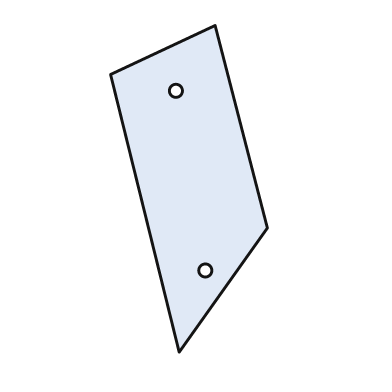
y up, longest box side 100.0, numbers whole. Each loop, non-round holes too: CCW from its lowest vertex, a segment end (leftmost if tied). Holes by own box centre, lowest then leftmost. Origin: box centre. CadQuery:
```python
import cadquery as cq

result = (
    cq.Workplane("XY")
    .moveTo(-3.0, -50.0)
    .lineTo(24.0, -12.0)
    .lineTo(8.0, 50.0)
    .lineTo(-24.0, 35.0)
    .close()
    .moveTo(5.0, -25.0)
    .circle(2.0)
    .moveTo(-4.0, 30.0)
    .circle(2.0)
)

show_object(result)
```